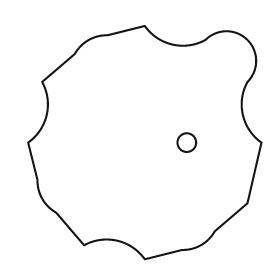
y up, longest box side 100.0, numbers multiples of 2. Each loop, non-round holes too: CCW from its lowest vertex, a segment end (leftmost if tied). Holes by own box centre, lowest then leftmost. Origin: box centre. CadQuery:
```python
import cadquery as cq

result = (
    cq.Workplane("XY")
    .moveTo(0.0, -50.0)
    .lineTo(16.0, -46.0)
    .threePointArc((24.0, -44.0), (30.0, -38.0))
    .lineTo(44.0, -26.0)
    .lineTo(50.0, 0.0)
    .threePointArc((42.0, 12.0), (44.0, 26.0))
    .threePointArc((44.0, 44.0), (26.0, 44.0))
    .threePointArc((12.0, 42.0), (0.0, 50.0))
    .lineTo(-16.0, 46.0)
    .threePointArc((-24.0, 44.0), (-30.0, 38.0))
    .lineTo(-44.0, 26.0)
    .threePointArc((-42.0, 12.0), (-50.0, 0.0))
    .lineTo(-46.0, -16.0)
    .threePointArc((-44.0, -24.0), (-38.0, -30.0))
    .lineTo(-26.0, -44.0)
    .threePointArc((-12.0, -42.0), (0.0, -50.0))
    .close()
    .moveTo(18.0, 0.0)
    .circle(4.0)
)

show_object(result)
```